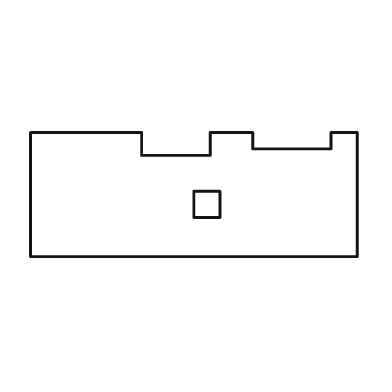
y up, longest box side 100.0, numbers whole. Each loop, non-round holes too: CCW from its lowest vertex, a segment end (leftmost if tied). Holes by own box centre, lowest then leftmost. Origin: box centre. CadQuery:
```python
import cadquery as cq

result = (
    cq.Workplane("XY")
    .moveTo(-50.0, -19.0)
    .lineTo(50.0, -19.0)
    .lineTo(50.0, 19.0)
    .lineTo(42.0, 19.0)
    .lineTo(42.0, 14.0)
    .lineTo(18.0, 14.0)
    .lineTo(18.0, 19.0)
    .lineTo(5.0, 19.0)
    .lineTo(5.0, 12.0)
    .lineTo(-16.0, 12.0)
    .lineTo(-16.0, 19.0)
    .lineTo(-50.0, 19.0)
    .close()
    .moveTo(0.0, -7.0)
    .lineTo(8.0, -7.0)
    .lineTo(8.0, 1.0)
    .lineTo(0.0, 1.0)
    .close()
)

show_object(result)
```